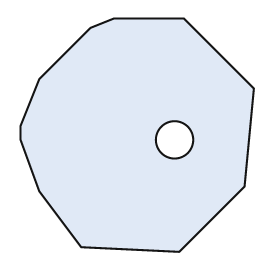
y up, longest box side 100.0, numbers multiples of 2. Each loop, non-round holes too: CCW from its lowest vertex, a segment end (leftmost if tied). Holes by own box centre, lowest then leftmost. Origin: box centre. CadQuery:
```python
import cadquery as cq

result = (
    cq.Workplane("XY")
    .moveTo(18.0, -50.0)
    .lineTo(46.0, -22.0)
    .lineTo(50.0, 20.0)
    .lineTo(20.0, 50.0)
    .lineTo(-10.0, 50.0)
    .lineTo(-20.0, 46.0)
    .lineTo(-42.0, 24.0)
    .lineTo(-50.0, 4.0)
    .lineTo(-50.0, -2.0)
    .lineTo(-42.0, -24.0)
    .lineTo(-24.0, -48.0)
    .close()
    .moveTo(16.0, -2.0)
    .circle(8.0)
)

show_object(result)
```